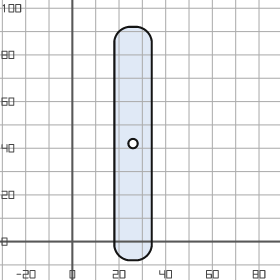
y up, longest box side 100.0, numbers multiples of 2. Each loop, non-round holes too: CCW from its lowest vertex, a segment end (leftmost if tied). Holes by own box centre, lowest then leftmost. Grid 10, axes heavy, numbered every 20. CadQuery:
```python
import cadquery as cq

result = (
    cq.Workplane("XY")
    .moveTo(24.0, -8.0)
    .lineTo(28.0, -8.0)
    .threePointArc((32.0, -6.0), (34.0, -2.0))
    .lineTo(34.0, 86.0)
    .threePointArc((32.0, 90.0), (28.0, 92.0))
    .lineTo(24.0, 92.0)
    .threePointArc((20.0, 90.0), (18.0, 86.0))
    .lineTo(18.0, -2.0)
    .threePointArc((20.0, -6.0), (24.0, -8.0))
    .close()
    .moveTo(26.0, 42.0)
    .circle(2.0)
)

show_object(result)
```